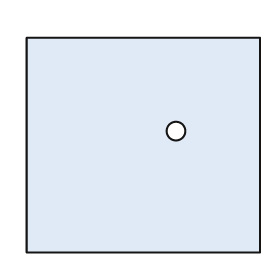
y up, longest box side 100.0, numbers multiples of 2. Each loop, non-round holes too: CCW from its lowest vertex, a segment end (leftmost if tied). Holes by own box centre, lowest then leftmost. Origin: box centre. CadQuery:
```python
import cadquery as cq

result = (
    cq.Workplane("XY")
    .moveTo(-50.0, -46.0)
    .lineTo(50.0, -46.0)
    .lineTo(50.0, 46.0)
    .lineTo(-50.0, 46.0)
    .close()
    .moveTo(14.0, 6.0)
    .circle(4.0)
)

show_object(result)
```